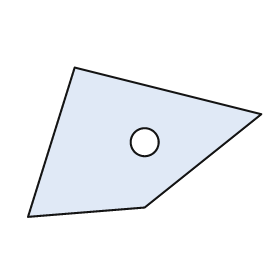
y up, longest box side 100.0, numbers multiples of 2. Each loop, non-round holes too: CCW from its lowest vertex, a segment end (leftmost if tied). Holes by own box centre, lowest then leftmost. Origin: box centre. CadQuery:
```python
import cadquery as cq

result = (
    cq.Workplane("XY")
    .moveTo(-50.0, -32.0)
    .lineTo(0.0, -28.0)
    .lineTo(50.0, 12.0)
    .lineTo(-30.0, 32.0)
    .close()
    .moveTo(0.0, 0.0)
    .circle(6.0)
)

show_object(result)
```